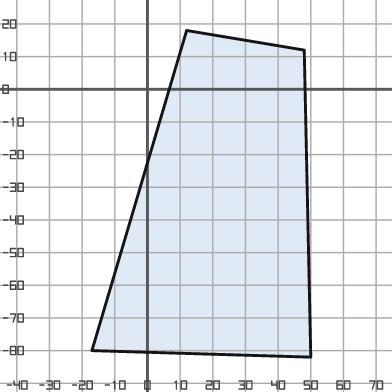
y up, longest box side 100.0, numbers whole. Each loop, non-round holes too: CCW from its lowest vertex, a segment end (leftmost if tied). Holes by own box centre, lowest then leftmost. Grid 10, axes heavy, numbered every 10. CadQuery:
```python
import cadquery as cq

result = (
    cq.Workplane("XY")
    .moveTo(50.0, -82.0)
    .lineTo(48.0, 12.0)
    .lineTo(12.0, 18.0)
    .lineTo(-17.0, -80.0)
    .close()
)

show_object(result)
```